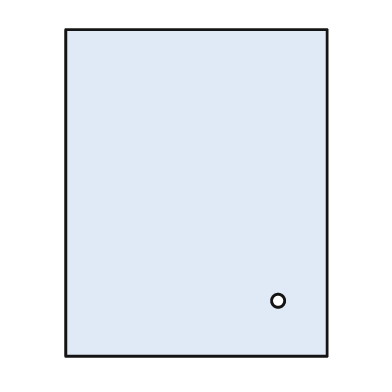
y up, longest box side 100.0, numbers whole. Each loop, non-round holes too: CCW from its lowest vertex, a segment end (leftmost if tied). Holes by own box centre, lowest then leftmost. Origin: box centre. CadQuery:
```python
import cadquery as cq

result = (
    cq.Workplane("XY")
    .moveTo(-40.0, -50.0)
    .lineTo(40.0, -50.0)
    .lineTo(40.0, 50.0)
    .lineTo(-40.0, 50.0)
    .close()
    .moveTo(25.0, -33.0)
    .circle(2.0)
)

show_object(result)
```